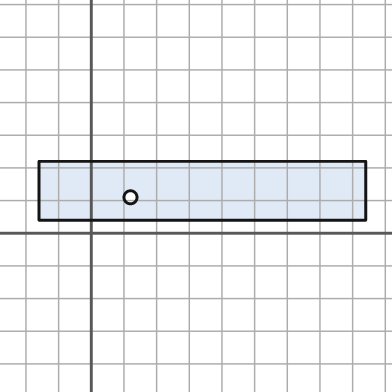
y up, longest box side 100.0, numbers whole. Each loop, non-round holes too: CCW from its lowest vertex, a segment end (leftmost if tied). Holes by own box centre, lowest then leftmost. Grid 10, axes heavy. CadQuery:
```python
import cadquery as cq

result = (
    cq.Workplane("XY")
    .moveTo(-16.0, 4.0)
    .lineTo(84.0, 4.0)
    .lineTo(84.0, 22.0)
    .lineTo(-16.0, 22.0)
    .close()
    .moveTo(12.0, 11.0)
    .circle(2.0)
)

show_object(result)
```